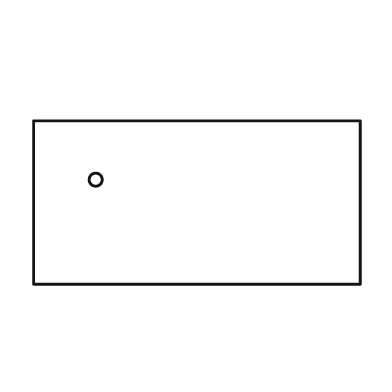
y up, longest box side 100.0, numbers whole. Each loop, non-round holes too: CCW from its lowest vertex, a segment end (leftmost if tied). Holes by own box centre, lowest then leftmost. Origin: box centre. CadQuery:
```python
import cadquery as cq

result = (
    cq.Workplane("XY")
    .moveTo(-50.0, -25.0)
    .lineTo(50.0, -25.0)
    .lineTo(50.0, 25.0)
    .lineTo(-50.0, 25.0)
    .close()
    .moveTo(-31.0, 7.0)
    .circle(2.0)
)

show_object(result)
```